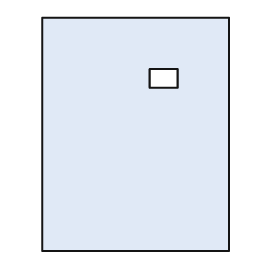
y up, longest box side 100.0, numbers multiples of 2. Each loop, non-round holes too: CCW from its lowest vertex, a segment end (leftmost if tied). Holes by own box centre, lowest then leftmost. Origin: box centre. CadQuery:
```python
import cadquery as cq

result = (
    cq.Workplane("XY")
    .moveTo(-40.0, -50.0)
    .lineTo(40.0, -50.0)
    .lineTo(40.0, 50.0)
    .lineTo(-40.0, 50.0)
    .close()
    .moveTo(6.0, 20.0)
    .lineTo(18.0, 20.0)
    .lineTo(18.0, 28.0)
    .lineTo(6.0, 28.0)
    .close()
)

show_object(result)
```